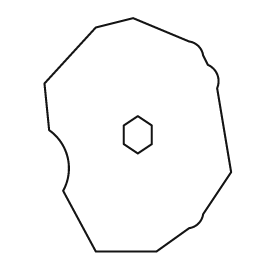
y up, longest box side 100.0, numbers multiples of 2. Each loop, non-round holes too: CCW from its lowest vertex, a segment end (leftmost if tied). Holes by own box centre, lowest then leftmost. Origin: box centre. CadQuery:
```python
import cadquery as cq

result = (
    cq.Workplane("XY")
    .moveTo(-18.0, -50.0)
    .lineTo(8.0, -50.0)
    .lineTo(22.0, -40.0)
    .threePointArc((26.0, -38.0), (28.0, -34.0))
    .lineTo(40.0, -16.0)
    .lineTo(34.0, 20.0)
    .threePointArc((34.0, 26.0), (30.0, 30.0))
    .lineTo(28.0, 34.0)
    .threePointArc((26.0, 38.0), (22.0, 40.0))
    .lineTo(-2.0, 50.0)
    .lineTo(-18.0, 46.0)
    .lineTo(-40.0, 22.0)
    .lineTo(-38.0, 2.0)
    .threePointArc((-30.0, -10.0), (-32.0, -24.0))
    .close()
    .moveTo(0.0, -8.0)
    .lineTo(6.0, -4.0)
    .lineTo(6.0, 4.0)
    .lineTo(0.0, 8.0)
    .lineTo(-6.0, 4.0)
    .lineTo(-6.0, -4.0)
    .close()
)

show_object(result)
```